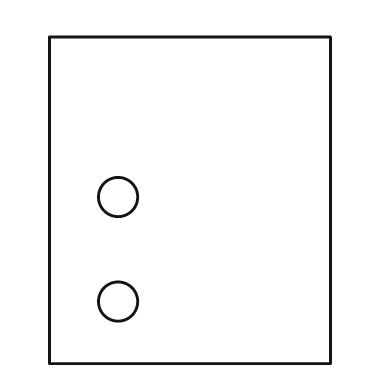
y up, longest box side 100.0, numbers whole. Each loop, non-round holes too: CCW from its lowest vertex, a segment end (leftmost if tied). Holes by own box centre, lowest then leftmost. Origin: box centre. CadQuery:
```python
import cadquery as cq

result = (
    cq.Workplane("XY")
    .moveTo(-43.0, -50.0)
    .lineTo(43.0, -50.0)
    .lineTo(43.0, 50.0)
    .lineTo(-43.0, 50.0)
    .close()
    .moveTo(-22.0, -31.0)
    .circle(6.0)
    .moveTo(-22.0, 1.0)
    .circle(6.0)
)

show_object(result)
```